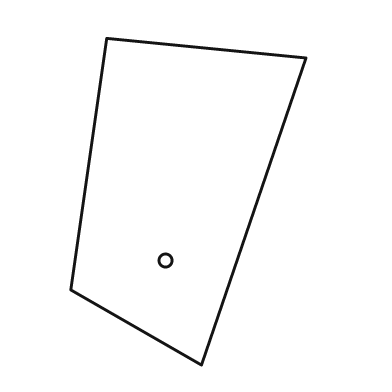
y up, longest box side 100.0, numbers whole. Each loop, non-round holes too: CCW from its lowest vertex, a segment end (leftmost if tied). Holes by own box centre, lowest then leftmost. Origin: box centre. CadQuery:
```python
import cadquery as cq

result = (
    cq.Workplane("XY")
    .moveTo(4.0, -50.0)
    .lineTo(36.0, 44.0)
    .lineTo(-25.0, 50.0)
    .lineTo(-36.0, -27.0)
    .close()
    .moveTo(-7.0, -18.0)
    .circle(2.0)
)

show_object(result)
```